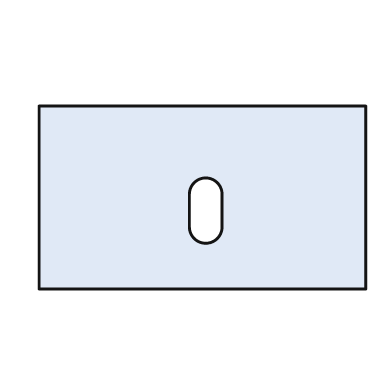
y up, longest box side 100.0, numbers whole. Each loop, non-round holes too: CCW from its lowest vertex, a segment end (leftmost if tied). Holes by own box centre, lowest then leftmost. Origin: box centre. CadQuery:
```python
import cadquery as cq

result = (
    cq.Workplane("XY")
    .moveTo(-50.0, -28.0)
    .lineTo(50.0, -28.0)
    .lineTo(50.0, 28.0)
    .lineTo(-50.0, 28.0)
    .close()
    .moveTo(-4.0, -9.0)
    .threePointArc((1.0, -14.0), (6.0, -9.0))
    .lineTo(6.0, 1.0)
    .threePointArc((1.0, 6.0), (-4.0, 1.0))
    .close()
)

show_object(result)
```